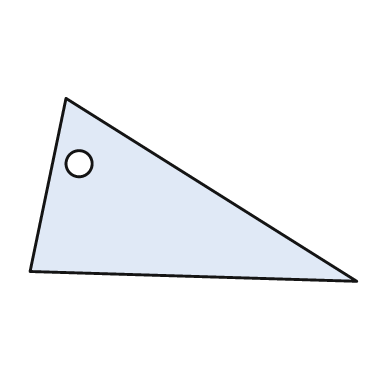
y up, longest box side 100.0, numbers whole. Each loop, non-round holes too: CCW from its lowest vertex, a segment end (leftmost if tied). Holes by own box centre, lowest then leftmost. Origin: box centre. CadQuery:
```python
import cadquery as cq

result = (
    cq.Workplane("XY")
    .moveTo(50.0, -28.0)
    .lineTo(-39.0, 28.0)
    .lineTo(-50.0, -25.0)
    .close()
    .moveTo(-35.0, 8.0)
    .circle(4.0)
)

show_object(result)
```